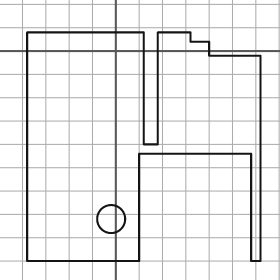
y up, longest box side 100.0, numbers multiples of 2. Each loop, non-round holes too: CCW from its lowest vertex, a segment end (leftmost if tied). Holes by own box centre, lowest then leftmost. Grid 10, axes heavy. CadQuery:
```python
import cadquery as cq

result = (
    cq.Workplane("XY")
    .moveTo(-38.0, -90.0)
    .lineTo(10.0, -90.0)
    .lineTo(10.0, -44.0)
    .lineTo(58.0, -44.0)
    .lineTo(58.0, -90.0)
    .lineTo(62.0, -90.0)
    .lineTo(62.0, -2.0)
    .lineTo(40.0, -2.0)
    .lineTo(40.0, 4.0)
    .lineTo(32.0, 4.0)
    .lineTo(32.0, 8.0)
    .lineTo(18.0, 8.0)
    .lineTo(18.0, -40.0)
    .lineTo(12.0, -40.0)
    .lineTo(12.0, 8.0)
    .lineTo(-38.0, 8.0)
    .close()
    .moveTo(-2.0, -72.0)
    .circle(6.0)
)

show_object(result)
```